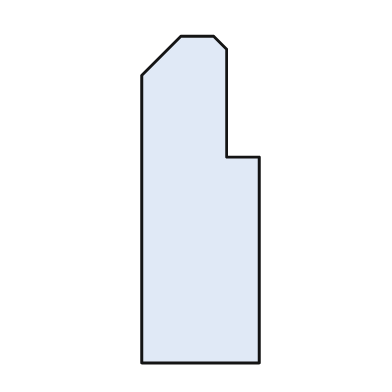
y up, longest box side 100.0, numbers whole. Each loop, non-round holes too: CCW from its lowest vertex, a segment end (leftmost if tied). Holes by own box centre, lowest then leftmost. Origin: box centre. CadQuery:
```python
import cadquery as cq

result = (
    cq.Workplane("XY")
    .moveTo(-18.0, -50.0)
    .lineTo(18.0, -50.0)
    .lineTo(18.0, 13.0)
    .lineTo(8.0, 13.0)
    .lineTo(8.0, 46.0)
    .lineTo(4.0, 50.0)
    .lineTo(-6.0, 50.0)
    .lineTo(-18.0, 38.0)
    .close()
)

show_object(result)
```